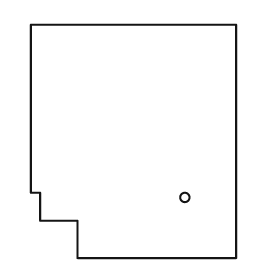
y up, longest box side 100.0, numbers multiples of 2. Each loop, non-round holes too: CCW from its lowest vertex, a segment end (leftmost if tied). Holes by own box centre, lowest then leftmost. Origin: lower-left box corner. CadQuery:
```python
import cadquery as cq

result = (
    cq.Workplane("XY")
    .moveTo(20.0, 0.0)
    .lineTo(88.0, 0.0)
    .lineTo(88.0, 100.0)
    .lineTo(0.0, 100.0)
    .lineTo(0.0, 28.0)
    .lineTo(4.0, 28.0)
    .lineTo(4.0, 16.0)
    .lineTo(20.0, 16.0)
    .close()
    .moveTo(66.0, 26.0)
    .circle(2.0)
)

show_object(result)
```